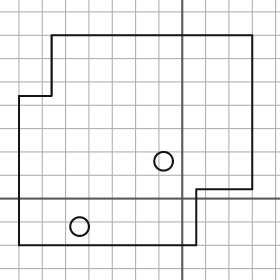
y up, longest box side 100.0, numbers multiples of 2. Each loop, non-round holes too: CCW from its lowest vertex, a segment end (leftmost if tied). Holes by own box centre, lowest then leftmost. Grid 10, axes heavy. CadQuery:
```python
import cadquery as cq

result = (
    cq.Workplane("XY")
    .moveTo(-70.0, -20.0)
    .lineTo(6.0, -20.0)
    .lineTo(6.0, 4.0)
    .lineTo(30.0, 4.0)
    .lineTo(30.0, 70.0)
    .lineTo(-56.0, 70.0)
    .lineTo(-56.0, 44.0)
    .lineTo(-70.0, 44.0)
    .close()
    .moveTo(-44.0, -12.0)
    .circle(4.0)
    .moveTo(-8.0, 16.0)
    .circle(4.0)
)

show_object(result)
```